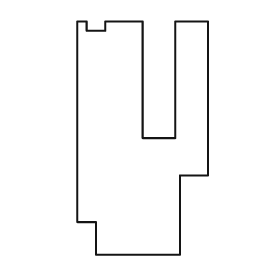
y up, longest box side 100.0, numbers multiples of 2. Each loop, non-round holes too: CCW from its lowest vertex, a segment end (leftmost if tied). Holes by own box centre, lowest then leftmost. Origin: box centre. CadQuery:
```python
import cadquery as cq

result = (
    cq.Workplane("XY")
    .moveTo(-20.0, -50.0)
    .lineTo(16.0, -50.0)
    .lineTo(16.0, -16.0)
    .lineTo(28.0, -16.0)
    .lineTo(28.0, 50.0)
    .lineTo(14.0, 50.0)
    .lineTo(14.0, 0.0)
    .lineTo(0.0, 0.0)
    .lineTo(0.0, 50.0)
    .lineTo(-16.0, 50.0)
    .lineTo(-16.0, 46.0)
    .lineTo(-24.0, 46.0)
    .lineTo(-24.0, 50.0)
    .lineTo(-28.0, 50.0)
    .lineTo(-28.0, -36.0)
    .lineTo(-20.0, -36.0)
    .close()
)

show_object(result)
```